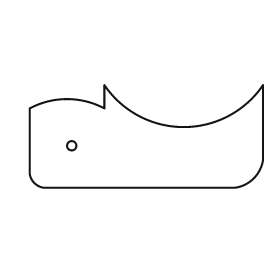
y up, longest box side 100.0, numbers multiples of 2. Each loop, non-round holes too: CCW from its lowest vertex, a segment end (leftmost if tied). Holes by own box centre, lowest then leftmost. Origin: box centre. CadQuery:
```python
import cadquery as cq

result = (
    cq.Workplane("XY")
    .moveTo(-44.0, -22.0)
    .lineTo(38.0, -22.0)
    .threePointArc((46.0, -18.0), (50.0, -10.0))
    .lineTo(50.0, 22.0)
    .threePointArc((16.0, 4.0), (-18.0, 22.0))
    .lineTo(-18.0, 12.0)
    .threePointArc((-34.0, 16.0), (-50.0, 12.0))
    .lineTo(-50.0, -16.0)
    .threePointArc((-48.0, -20.0), (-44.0, -22.0))
    .close()
    .moveTo(-32.0, -4.0)
    .circle(2.0)
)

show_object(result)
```